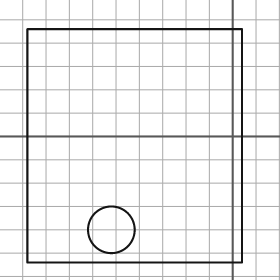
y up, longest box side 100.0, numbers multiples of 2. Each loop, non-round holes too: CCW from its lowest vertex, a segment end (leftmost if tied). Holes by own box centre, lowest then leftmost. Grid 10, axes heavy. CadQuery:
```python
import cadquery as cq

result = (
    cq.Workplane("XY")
    .moveTo(-88.0, -54.0)
    .lineTo(4.0, -54.0)
    .lineTo(4.0, 46.0)
    .lineTo(-88.0, 46.0)
    .close()
    .moveTo(-52.0, -40.0)
    .circle(10.0)
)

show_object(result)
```